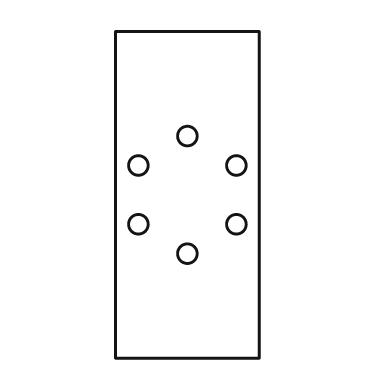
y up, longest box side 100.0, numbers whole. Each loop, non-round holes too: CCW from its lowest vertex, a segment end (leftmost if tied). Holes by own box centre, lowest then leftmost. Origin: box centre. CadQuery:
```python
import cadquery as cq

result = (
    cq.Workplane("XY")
    .moveTo(-22.0, -50.0)
    .lineTo(22.0, -50.0)
    .lineTo(22.0, 50.0)
    .lineTo(-22.0, 50.0)
    .close()
    .moveTo(0.0, -18.0)
    .circle(3.0)
    .moveTo(-15.0, -9.0)
    .circle(3.0)
    .moveTo(15.0, -9.0)
    .circle(3.0)
    .moveTo(-15.0, 9.0)
    .circle(3.0)
    .moveTo(15.0, 9.0)
    .circle(3.0)
    .moveTo(0.0, 18.0)
    .circle(3.0)
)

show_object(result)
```